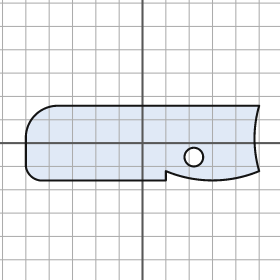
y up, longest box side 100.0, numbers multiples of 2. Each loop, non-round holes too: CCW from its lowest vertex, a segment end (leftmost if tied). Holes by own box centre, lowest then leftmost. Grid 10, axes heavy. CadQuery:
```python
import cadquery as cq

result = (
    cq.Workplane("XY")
    .moveTo(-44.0, -16.0)
    .lineTo(10.0, -16.0)
    .lineTo(10.0, -12.0)
    .threePointArc((30.0, -16.0), (50.0, -12.0))
    .threePointArc((48.0, 2.0), (50.0, 16.0))
    .lineTo(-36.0, 16.0)
    .threePointArc((-46.0, 12.0), (-50.0, 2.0))
    .lineTo(-50.0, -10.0)
    .threePointArc((-48.0, -14.0), (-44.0, -16.0))
    .close()
    .moveTo(22.0, -6.0)
    .circle(4.0)
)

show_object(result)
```